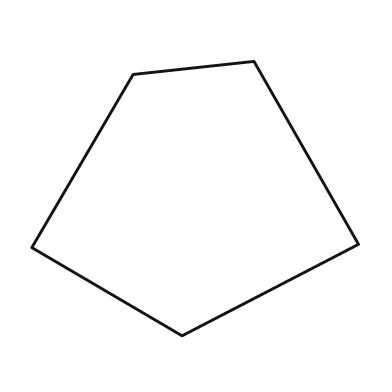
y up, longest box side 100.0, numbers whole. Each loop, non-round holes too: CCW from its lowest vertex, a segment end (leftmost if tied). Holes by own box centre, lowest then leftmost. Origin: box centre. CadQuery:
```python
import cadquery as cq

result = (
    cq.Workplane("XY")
    .moveTo(-4.0, -42.0)
    .lineTo(50.0, -14.0)
    .lineTo(18.0, 42.0)
    .lineTo(-19.0, 38.0)
    .lineTo(-50.0, -15.0)
    .close()
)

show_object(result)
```